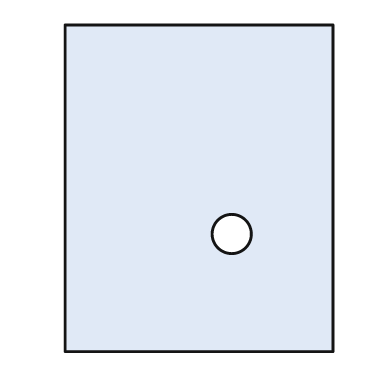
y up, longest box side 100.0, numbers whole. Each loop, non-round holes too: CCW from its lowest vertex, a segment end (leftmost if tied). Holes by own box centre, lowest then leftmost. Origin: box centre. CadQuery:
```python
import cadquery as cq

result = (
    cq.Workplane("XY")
    .moveTo(-41.0, -50.0)
    .lineTo(41.0, -50.0)
    .lineTo(41.0, 50.0)
    .lineTo(-41.0, 50.0)
    .close()
    .moveTo(10.0, -14.0)
    .circle(6.0)
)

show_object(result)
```